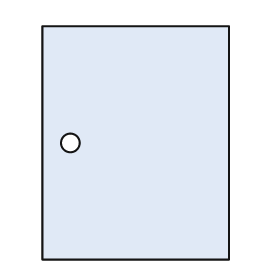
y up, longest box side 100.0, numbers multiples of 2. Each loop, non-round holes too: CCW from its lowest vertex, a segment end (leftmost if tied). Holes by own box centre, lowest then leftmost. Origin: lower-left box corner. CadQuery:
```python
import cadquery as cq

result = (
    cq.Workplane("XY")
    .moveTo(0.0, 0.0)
    .lineTo(80.0, 0.0)
    .lineTo(80.0, 100.0)
    .lineTo(0.0, 100.0)
    .close()
    .moveTo(12.0, 50.0)
    .circle(4.0)
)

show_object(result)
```